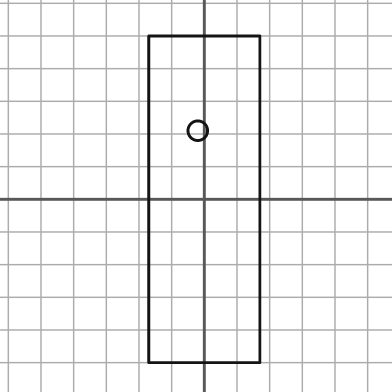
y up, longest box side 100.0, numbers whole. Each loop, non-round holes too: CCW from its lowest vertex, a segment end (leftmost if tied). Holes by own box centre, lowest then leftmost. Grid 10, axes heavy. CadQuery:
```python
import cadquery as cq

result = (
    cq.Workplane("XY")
    .moveTo(-17.0, -50.0)
    .lineTo(17.0, -50.0)
    .lineTo(17.0, 50.0)
    .lineTo(-17.0, 50.0)
    .close()
    .moveTo(-2.0, 21.0)
    .circle(3.0)
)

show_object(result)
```